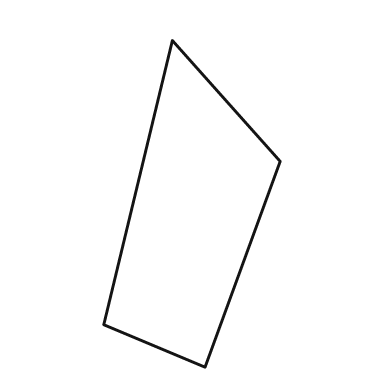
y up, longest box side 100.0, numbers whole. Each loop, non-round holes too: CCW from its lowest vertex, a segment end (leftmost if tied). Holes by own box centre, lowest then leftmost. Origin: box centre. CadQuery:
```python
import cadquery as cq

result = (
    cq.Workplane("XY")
    .moveTo(4.0, -50.0)
    .lineTo(27.0, 13.0)
    .lineTo(-6.0, 50.0)
    .lineTo(-27.0, -37.0)
    .close()
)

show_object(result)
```